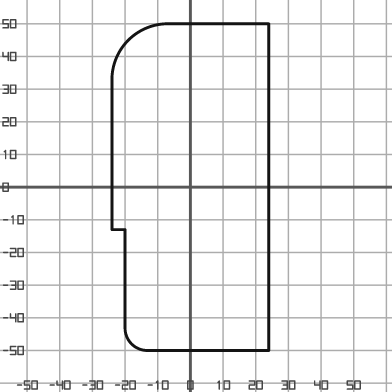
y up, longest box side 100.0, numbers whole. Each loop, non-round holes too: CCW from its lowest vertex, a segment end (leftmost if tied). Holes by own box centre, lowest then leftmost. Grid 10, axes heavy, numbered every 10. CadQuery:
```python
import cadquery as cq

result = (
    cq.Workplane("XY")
    .moveTo(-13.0, -50.0)
    .lineTo(24.0, -50.0)
    .lineTo(24.0, 50.0)
    .lineTo(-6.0, 50.0)
    .threePointArc((-19.0, 45.0), (-24.0, 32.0))
    .lineTo(-24.0, -13.0)
    .lineTo(-20.0, -13.0)
    .lineTo(-20.0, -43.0)
    .threePointArc((-18.0, -48.0), (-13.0, -50.0))
    .close()
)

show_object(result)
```